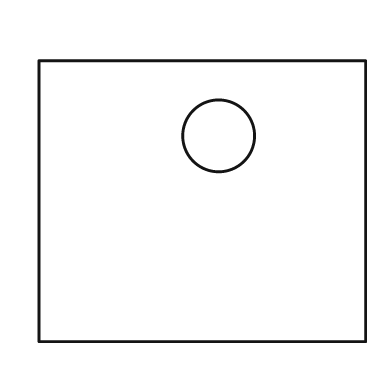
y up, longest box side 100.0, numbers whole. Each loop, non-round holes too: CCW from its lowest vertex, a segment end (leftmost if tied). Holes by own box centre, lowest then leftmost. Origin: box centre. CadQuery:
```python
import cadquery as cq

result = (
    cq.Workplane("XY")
    .moveTo(-50.0, -43.0)
    .lineTo(50.0, -43.0)
    .lineTo(50.0, 43.0)
    .lineTo(-50.0, 43.0)
    .close()
    .moveTo(5.0, 20.0)
    .circle(11.0)
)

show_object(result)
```